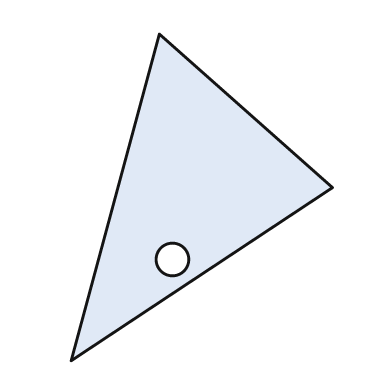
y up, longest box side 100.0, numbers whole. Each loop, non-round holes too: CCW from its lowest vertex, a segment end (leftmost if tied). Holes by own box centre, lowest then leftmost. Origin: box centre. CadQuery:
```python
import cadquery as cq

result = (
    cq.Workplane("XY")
    .moveTo(-40.0, -50.0)
    .lineTo(40.0, 3.0)
    .lineTo(-13.0, 50.0)
    .close()
    .moveTo(-9.0, -19.0)
    .circle(5.0)
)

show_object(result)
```